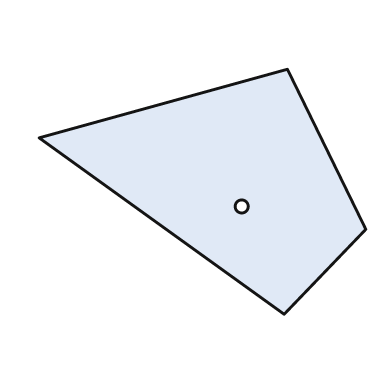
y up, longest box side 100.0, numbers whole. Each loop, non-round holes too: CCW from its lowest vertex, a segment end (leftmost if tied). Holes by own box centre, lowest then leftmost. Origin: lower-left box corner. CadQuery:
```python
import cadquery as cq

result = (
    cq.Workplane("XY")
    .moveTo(75.0, 0.0)
    .lineTo(100.0, 26.0)
    .lineTo(76.0, 75.0)
    .lineTo(0.0, 54.0)
    .close()
    .moveTo(62.0, 33.0)
    .circle(2.0)
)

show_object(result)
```